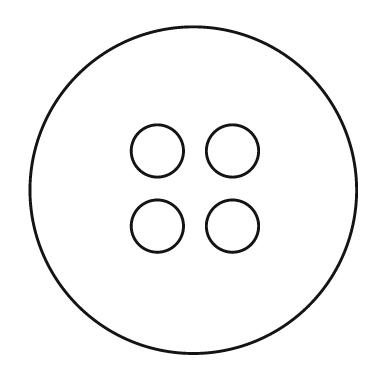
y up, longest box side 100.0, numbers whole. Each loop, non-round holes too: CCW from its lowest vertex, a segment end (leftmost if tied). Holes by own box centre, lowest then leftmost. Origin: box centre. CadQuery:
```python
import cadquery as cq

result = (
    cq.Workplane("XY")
    .moveTo(0.0, 0.0)
    .circle(50.0)
    .moveTo(-11.0, -11.0)
    .circle(8.0)
    .moveTo(12.0, -11.0)
    .circle(8.0)
    .moveTo(-11.0, 12.0)
    .circle(8.0)
    .moveTo(12.0, 12.0)
    .circle(8.0)
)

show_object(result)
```